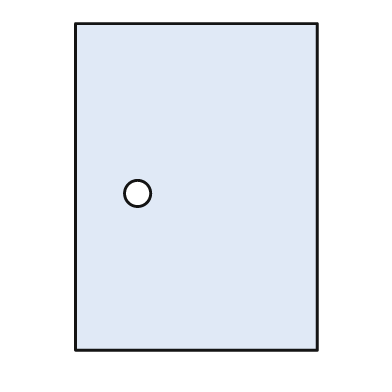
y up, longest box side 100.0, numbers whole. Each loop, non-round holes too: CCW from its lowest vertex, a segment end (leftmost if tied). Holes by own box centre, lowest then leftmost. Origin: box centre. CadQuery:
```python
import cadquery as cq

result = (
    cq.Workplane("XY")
    .moveTo(-37.0, -50.0)
    .lineTo(37.0, -50.0)
    .lineTo(37.0, 50.0)
    .lineTo(-37.0, 50.0)
    .close()
    .moveTo(-18.0, -2.0)
    .circle(4.0)
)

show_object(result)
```